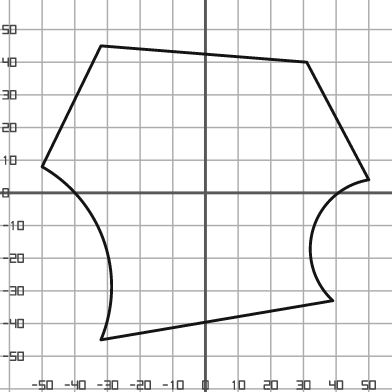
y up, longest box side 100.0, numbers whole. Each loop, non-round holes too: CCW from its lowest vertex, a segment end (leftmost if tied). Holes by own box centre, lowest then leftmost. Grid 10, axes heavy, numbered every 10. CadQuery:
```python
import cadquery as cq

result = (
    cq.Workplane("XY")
    .moveTo(-32.0, -45.0)
    .lineTo(39.0, -33.0)
    .threePointArc((33.0, -11.0), (50.0, 4.0))
    .lineTo(31.0, 40.0)
    .lineTo(-32.0, 45.0)
    .lineTo(-50.0, 8.0)
    .threePointArc((-31.0, -15.0), (-32.0, -45.0))
    .close()
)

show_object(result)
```